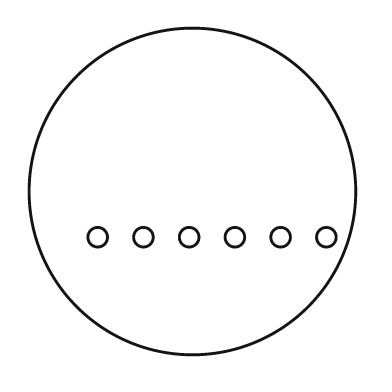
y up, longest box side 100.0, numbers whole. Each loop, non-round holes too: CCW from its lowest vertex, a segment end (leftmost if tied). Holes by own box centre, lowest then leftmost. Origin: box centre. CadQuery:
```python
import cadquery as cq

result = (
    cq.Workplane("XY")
    .moveTo(0.0, 0.0)
    .circle(50.0)
    .moveTo(-29.0, -14.0)
    .circle(3.0)
    .moveTo(-15.0, -14.0)
    .circle(3.0)
    .moveTo(-1.0, -14.0)
    .circle(3.0)
    .moveTo(13.0, -14.0)
    .circle(3.0)
    .moveTo(27.0, -14.0)
    .circle(3.0)
    .moveTo(41.0, -14.0)
    .circle(3.0)
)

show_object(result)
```